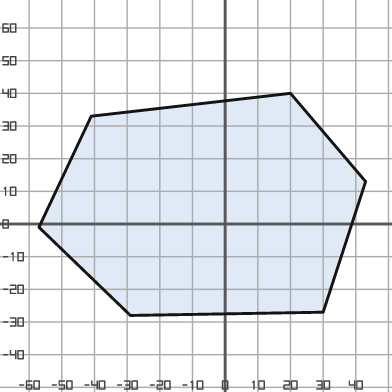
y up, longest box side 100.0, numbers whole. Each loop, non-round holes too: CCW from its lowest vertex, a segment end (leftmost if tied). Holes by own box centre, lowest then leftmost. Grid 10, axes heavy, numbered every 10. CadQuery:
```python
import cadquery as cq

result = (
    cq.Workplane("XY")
    .moveTo(-29.0, -28.0)
    .lineTo(30.0, -27.0)
    .lineTo(43.0, 13.0)
    .lineTo(20.0, 40.0)
    .lineTo(-41.0, 33.0)
    .lineTo(-57.0, -1.0)
    .close()
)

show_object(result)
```